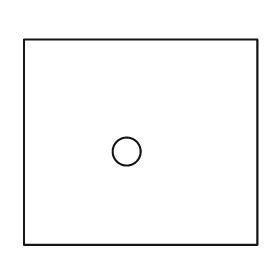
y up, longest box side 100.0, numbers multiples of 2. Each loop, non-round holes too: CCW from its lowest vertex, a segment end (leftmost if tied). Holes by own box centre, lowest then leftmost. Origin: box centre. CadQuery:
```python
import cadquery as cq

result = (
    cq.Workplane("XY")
    .moveTo(-50.0, -44.0)
    .lineTo(50.0, -44.0)
    .lineTo(50.0, 44.0)
    .lineTo(-50.0, 44.0)
    .close()
    .moveTo(-6.0, -4.0)
    .circle(6.0)
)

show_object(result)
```